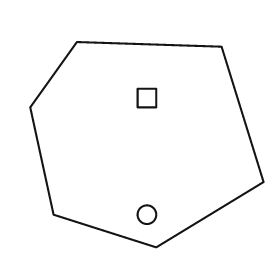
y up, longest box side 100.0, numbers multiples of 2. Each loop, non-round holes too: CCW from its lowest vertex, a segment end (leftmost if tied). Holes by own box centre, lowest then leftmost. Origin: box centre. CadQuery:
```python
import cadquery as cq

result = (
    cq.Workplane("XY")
    .moveTo(4.0, -44.0)
    .lineTo(50.0, -16.0)
    .lineTo(32.0, 42.0)
    .lineTo(-30.0, 44.0)
    .lineTo(-50.0, 16.0)
    .lineTo(-40.0, -30.0)
    .close()
    .moveTo(0.0, -30.0)
    .circle(4.0)
    .moveTo(-4.0, 16.0)
    .lineTo(4.0, 16.0)
    .lineTo(4.0, 24.0)
    .lineTo(-4.0, 24.0)
    .close()
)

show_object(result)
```